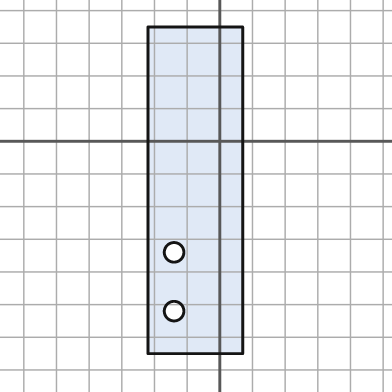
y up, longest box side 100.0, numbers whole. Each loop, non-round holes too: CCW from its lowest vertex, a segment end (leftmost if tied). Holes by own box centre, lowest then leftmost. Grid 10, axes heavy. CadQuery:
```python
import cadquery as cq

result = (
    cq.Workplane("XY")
    .moveTo(-22.0, -65.0)
    .lineTo(7.0, -65.0)
    .lineTo(7.0, 35.0)
    .lineTo(-22.0, 35.0)
    .close()
    .moveTo(-14.0, -52.0)
    .circle(3.0)
    .moveTo(-14.0, -34.0)
    .circle(3.0)
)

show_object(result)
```